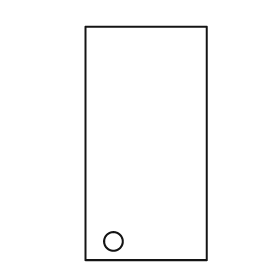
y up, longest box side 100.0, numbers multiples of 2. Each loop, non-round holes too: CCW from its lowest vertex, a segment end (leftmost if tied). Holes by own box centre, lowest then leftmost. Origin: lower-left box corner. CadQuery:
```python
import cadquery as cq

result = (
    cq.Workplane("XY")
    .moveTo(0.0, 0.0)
    .lineTo(52.0, 0.0)
    .lineTo(52.0, 100.0)
    .lineTo(0.0, 100.0)
    .close()
    .moveTo(12.0, 8.0)
    .circle(4.0)
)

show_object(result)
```